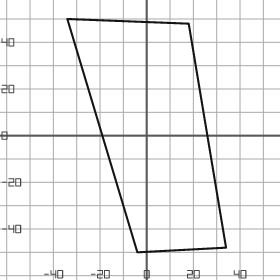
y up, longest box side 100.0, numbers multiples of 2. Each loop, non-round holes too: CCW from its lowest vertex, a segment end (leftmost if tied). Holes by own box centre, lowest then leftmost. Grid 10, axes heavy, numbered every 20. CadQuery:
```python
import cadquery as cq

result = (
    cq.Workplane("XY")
    .moveTo(-4.0, -50.0)
    .lineTo(34.0, -48.0)
    .lineTo(18.0, 48.0)
    .lineTo(-34.0, 50.0)
    .close()
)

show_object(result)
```